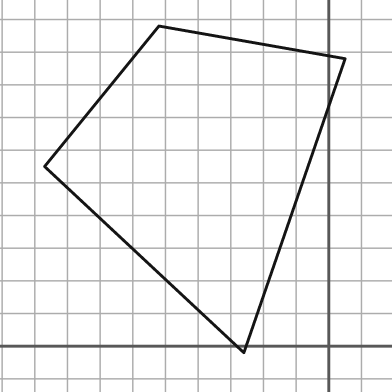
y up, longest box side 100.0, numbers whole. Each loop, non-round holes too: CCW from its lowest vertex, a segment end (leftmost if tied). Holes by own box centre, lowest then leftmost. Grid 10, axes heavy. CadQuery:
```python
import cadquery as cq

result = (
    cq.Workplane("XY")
    .moveTo(-26.0, -2.0)
    .lineTo(5.0, 88.0)
    .lineTo(-52.0, 98.0)
    .lineTo(-87.0, 55.0)
    .close()
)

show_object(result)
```